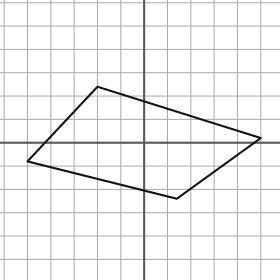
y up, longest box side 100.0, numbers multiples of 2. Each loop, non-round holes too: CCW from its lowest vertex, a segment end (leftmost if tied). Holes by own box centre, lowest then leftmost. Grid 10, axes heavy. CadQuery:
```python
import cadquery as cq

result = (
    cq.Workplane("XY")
    .moveTo(14.0, -24.0)
    .lineTo(50.0, 2.0)
    .lineTo(-20.0, 24.0)
    .lineTo(-50.0, -8.0)
    .close()
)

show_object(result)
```